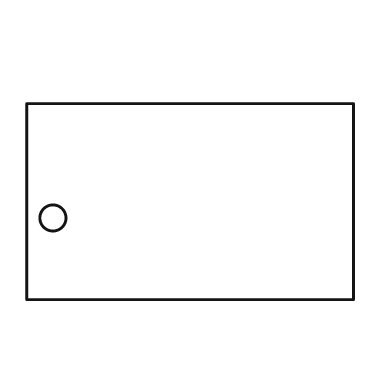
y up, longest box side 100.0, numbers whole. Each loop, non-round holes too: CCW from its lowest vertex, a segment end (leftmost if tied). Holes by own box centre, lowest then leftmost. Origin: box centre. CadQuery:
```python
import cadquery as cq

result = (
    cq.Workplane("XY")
    .moveTo(-50.0, -30.0)
    .lineTo(50.0, -30.0)
    .lineTo(50.0, 30.0)
    .lineTo(-50.0, 30.0)
    .close()
    .moveTo(-42.0, -5.0)
    .circle(4.0)
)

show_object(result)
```